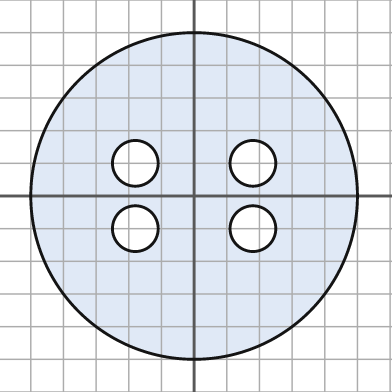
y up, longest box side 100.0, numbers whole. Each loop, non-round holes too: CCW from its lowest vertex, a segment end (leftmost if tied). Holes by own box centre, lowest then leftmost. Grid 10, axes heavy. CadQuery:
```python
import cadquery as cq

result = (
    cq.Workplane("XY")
    .moveTo(0.0, 0.0)
    .circle(50.0)
    .moveTo(-18.0, -10.0)
    .circle(7.0)
    .moveTo(18.0, -10.0)
    .circle(7.0)
    .moveTo(-18.0, 10.0)
    .circle(7.0)
    .moveTo(18.0, 10.0)
    .circle(7.0)
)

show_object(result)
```